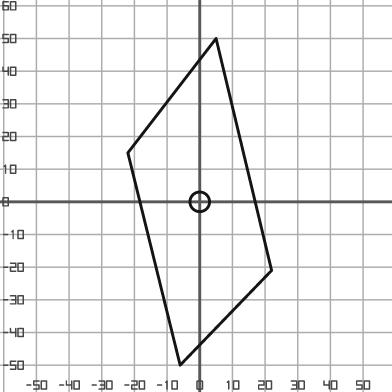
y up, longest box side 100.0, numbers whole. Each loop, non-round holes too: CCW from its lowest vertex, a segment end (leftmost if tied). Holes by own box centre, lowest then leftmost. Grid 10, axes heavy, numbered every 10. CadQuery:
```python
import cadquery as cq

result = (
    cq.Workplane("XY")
    .moveTo(-6.0, -50.0)
    .lineTo(22.0, -21.0)
    .lineTo(5.0, 50.0)
    .lineTo(-22.0, 15.0)
    .close()
    .moveTo(0.0, 0.0)
    .circle(3.0)
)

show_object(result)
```